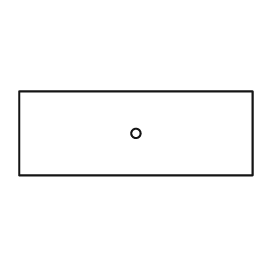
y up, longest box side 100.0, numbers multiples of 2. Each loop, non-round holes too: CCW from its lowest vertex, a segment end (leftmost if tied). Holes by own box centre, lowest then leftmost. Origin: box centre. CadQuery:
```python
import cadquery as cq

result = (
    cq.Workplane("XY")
    .moveTo(-50.0, -18.0)
    .lineTo(50.0, -18.0)
    .lineTo(50.0, 18.0)
    .lineTo(-50.0, 18.0)
    .close()
    .moveTo(0.0, 0.0)
    .circle(2.0)
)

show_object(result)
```